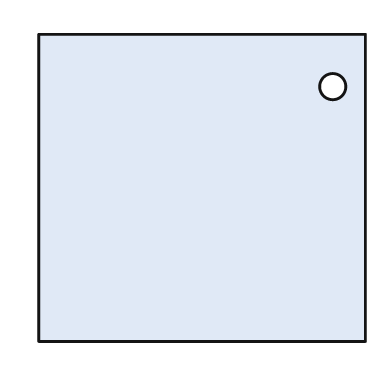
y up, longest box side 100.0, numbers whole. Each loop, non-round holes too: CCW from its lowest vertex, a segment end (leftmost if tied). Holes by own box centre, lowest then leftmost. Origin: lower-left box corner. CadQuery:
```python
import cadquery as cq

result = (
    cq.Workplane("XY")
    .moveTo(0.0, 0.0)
    .lineTo(100.0, 0.0)
    .lineTo(100.0, 94.0)
    .lineTo(0.0, 94.0)
    .close()
    .moveTo(90.0, 78.0)
    .circle(4.0)
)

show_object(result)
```